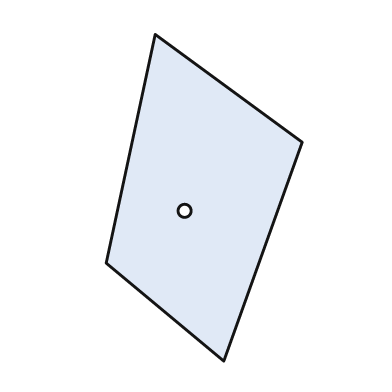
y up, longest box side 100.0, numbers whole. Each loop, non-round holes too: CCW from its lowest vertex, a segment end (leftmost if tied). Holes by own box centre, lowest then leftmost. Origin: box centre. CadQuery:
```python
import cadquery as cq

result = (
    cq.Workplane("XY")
    .moveTo(6.0, -50.0)
    .lineTo(30.0, 17.0)
    .lineTo(-15.0, 50.0)
    .lineTo(-30.0, -20.0)
    .close()
    .moveTo(-6.0, -4.0)
    .circle(2.0)
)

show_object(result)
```